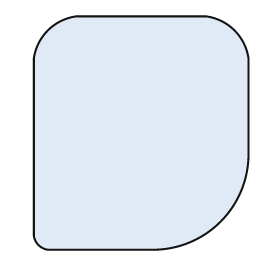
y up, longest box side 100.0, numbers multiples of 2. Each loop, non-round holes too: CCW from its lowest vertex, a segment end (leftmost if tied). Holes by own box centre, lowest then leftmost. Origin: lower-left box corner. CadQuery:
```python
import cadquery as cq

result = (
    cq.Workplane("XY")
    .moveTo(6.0, 0.0)
    .lineTo(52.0, 0.0)
    .threePointArc((80.0, 12.0), (92.0, 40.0))
    .lineTo(92.0, 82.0)
    .threePointArc((86.0, 94.0), (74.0, 100.0))
    .lineTo(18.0, 100.0)
    .threePointArc((6.0, 94.0), (0.0, 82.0))
    .lineTo(0.0, 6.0)
    .threePointArc((2.0, 2.0), (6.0, 0.0))
    .close()
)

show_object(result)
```